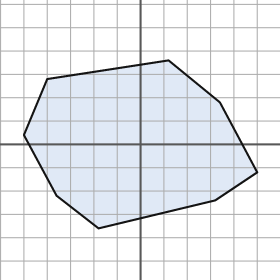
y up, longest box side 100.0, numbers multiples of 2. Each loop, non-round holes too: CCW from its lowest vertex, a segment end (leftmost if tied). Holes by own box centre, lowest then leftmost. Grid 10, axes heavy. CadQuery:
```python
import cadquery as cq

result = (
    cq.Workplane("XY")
    .moveTo(-18.0, -36.0)
    .lineTo(32.0, -24.0)
    .lineTo(50.0, -12.0)
    .lineTo(34.0, 18.0)
    .lineTo(12.0, 36.0)
    .lineTo(-40.0, 28.0)
    .lineTo(-50.0, 4.0)
    .lineTo(-36.0, -22.0)
    .close()
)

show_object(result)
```